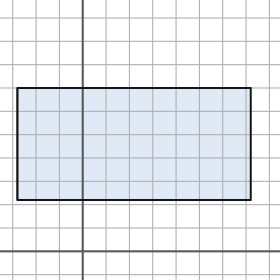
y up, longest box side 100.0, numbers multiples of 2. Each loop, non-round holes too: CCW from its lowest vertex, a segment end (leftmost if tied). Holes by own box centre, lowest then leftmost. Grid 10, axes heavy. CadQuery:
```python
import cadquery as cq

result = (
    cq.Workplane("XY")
    .moveTo(-28.0, 22.0)
    .lineTo(72.0, 22.0)
    .lineTo(72.0, 70.0)
    .lineTo(-28.0, 70.0)
    .close()
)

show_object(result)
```